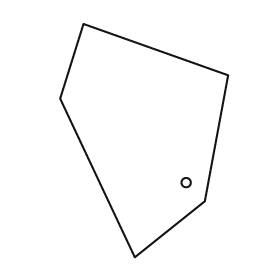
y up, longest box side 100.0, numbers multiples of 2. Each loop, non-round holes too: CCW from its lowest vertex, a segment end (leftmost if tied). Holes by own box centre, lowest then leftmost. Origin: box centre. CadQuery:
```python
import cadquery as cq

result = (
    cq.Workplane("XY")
    .moveTo(-4.0, -50.0)
    .lineTo(26.0, -26.0)
    .lineTo(36.0, 28.0)
    .lineTo(-26.0, 50.0)
    .lineTo(-36.0, 18.0)
    .close()
    .moveTo(18.0, -18.0)
    .circle(2.0)
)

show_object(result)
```